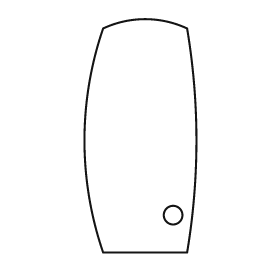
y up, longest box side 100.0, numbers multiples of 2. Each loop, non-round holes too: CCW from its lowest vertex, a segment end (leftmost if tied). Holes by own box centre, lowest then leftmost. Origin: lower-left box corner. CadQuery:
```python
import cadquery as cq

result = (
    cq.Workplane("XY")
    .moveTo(8.0, 0.0)
    .lineTo(44.0, 0.0)
    .threePointArc((48.0, 48.0), (44.0, 96.0))
    .threePointArc((26.0, 100.0), (8.0, 96.0))
    .threePointArc((0.0, 48.0), (8.0, 0.0))
    .close()
    .moveTo(38.0, 16.0)
    .circle(4.0)
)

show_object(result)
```